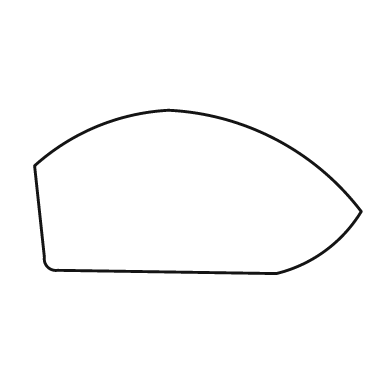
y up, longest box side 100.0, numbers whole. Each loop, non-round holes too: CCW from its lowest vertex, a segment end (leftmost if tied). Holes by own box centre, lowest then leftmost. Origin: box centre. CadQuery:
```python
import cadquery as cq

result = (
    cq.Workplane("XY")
    .moveTo(24.0, -25.0)
    .threePointArc((39.0, -18.0), (50.0, -6.0))
    .threePointArc((24.0, 16.0), (-9.0, 25.0))
    .threePointArc((-31.0, 20.0), (-50.0, 8.0))
    .lineTo(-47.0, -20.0)
    .threePointArc((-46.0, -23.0), (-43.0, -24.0))
    .close()
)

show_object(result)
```